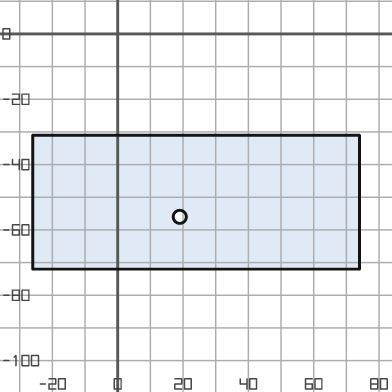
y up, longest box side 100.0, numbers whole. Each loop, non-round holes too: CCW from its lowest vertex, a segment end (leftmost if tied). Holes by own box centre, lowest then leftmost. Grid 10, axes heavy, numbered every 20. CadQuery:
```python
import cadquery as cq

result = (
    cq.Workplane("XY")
    .moveTo(-26.0, -72.0)
    .lineTo(74.0, -72.0)
    .lineTo(74.0, -31.0)
    .lineTo(-26.0, -31.0)
    .close()
    .moveTo(19.0, -56.0)
    .circle(2.0)
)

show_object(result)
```